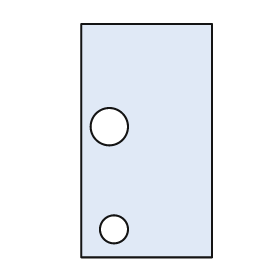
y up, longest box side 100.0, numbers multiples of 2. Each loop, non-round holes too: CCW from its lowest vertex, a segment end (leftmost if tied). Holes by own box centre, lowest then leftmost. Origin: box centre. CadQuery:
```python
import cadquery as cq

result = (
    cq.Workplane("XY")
    .moveTo(-28.0, -50.0)
    .lineTo(28.0, -50.0)
    .lineTo(28.0, 50.0)
    .lineTo(-28.0, 50.0)
    .close()
    .moveTo(-14.0, -38.0)
    .circle(6.0)
    .moveTo(-16.0, 6.0)
    .circle(8.0)
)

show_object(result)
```